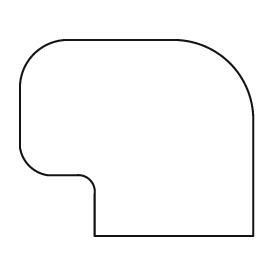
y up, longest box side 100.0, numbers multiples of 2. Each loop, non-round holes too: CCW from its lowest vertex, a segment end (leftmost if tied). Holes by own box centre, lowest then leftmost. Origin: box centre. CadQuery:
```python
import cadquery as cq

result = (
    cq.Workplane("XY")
    .moveTo(-18.0, -42.0)
    .lineTo(50.0, -42.0)
    .lineTo(50.0, 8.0)
    .threePointArc((40.0, 32.0), (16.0, 42.0))
    .lineTo(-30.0, 42.0)
    .threePointArc((-44.0, 36.0), (-50.0, 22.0))
    .lineTo(-50.0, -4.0)
    .threePointArc((-46.0, -12.0), (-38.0, -16.0))
    .lineTo(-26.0, -16.0)
    .threePointArc((-20.0, -18.0), (-18.0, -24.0))
    .close()
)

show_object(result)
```